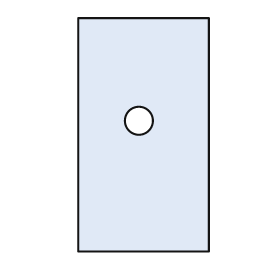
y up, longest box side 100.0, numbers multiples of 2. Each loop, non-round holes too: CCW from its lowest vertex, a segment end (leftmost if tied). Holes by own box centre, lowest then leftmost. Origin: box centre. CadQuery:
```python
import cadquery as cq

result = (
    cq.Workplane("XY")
    .moveTo(-28.0, -50.0)
    .lineTo(28.0, -50.0)
    .lineTo(28.0, 50.0)
    .lineTo(-28.0, 50.0)
    .close()
    .moveTo(-2.0, 6.0)
    .circle(6.0)
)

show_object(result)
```